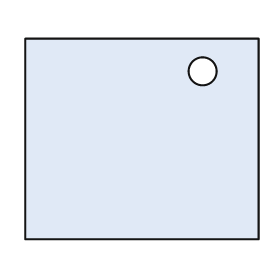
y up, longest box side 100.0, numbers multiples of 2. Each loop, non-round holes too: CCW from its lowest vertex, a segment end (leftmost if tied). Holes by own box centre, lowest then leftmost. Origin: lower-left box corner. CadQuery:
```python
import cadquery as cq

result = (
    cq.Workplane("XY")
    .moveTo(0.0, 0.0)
    .lineTo(100.0, 0.0)
    .lineTo(100.0, 86.0)
    .lineTo(0.0, 86.0)
    .close()
    .moveTo(76.0, 72.0)
    .circle(6.0)
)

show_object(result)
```